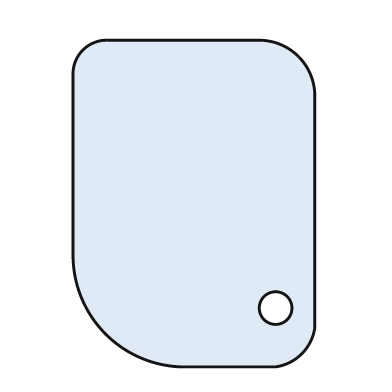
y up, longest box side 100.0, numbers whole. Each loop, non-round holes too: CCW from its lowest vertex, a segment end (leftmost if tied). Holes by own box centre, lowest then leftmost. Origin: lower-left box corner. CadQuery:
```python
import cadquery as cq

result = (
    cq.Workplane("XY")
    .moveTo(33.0, 0.0)
    .lineTo(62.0, 0.0)
    .threePointArc((70.0, 4.0), (74.0, 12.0))
    .lineTo(74.0, 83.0)
    .threePointArc((69.0, 95.0), (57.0, 100.0))
    .lineTo(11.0, 100.0)
    .threePointArc((3.0, 97.0), (0.0, 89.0))
    .lineTo(0.0, 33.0)
    .threePointArc((10.0, 10.0), (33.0, 0.0))
    .close()
    .moveTo(62.0, 18.0)
    .circle(5.0)
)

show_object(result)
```